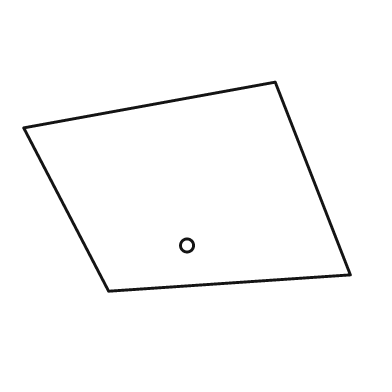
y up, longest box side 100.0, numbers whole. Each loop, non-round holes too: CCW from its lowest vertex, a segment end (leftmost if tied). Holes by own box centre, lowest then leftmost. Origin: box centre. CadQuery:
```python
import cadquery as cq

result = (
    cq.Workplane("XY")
    .moveTo(-24.0, -32.0)
    .lineTo(50.0, -27.0)
    .lineTo(27.0, 32.0)
    .lineTo(-50.0, 18.0)
    .close()
    .moveTo(0.0, -18.0)
    .circle(2.0)
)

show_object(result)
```